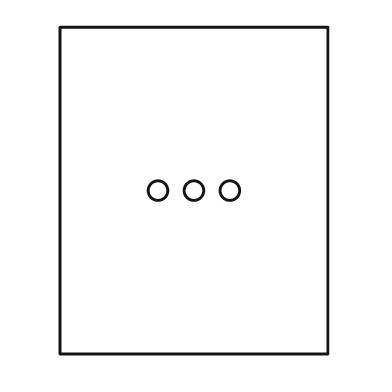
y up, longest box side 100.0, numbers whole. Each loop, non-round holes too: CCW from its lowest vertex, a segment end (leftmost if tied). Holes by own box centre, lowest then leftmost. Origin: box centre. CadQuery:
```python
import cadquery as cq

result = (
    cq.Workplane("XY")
    .moveTo(-41.0, -50.0)
    .lineTo(41.0, -50.0)
    .lineTo(41.0, 50.0)
    .lineTo(-41.0, 50.0)
    .close()
    .moveTo(-11.0, 0.0)
    .circle(3.0)
    .moveTo(0.0, 0.0)
    .circle(3.0)
    .moveTo(11.0, 0.0)
    .circle(3.0)
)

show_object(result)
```